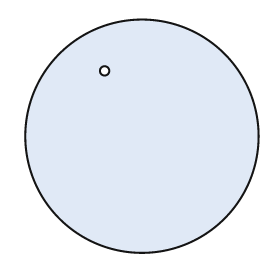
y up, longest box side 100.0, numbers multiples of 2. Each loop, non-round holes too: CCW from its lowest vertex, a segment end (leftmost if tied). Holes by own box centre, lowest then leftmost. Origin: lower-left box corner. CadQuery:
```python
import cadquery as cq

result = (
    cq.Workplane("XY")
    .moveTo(50.0, 50.0)
    .circle(50.0)
    .moveTo(34.0, 78.0)
    .circle(2.0)
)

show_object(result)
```